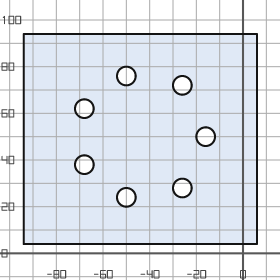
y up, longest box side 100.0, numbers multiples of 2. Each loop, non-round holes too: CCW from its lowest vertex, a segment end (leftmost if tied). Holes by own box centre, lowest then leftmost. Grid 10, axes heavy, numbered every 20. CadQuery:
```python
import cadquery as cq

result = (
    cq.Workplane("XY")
    .moveTo(-94.0, 4.0)
    .lineTo(6.0, 4.0)
    .lineTo(6.0, 94.0)
    .lineTo(-94.0, 94.0)
    .close()
    .moveTo(-50.0, 24.0)
    .circle(4.0)
    .moveTo(-26.0, 28.0)
    .circle(4.0)
    .moveTo(-68.0, 38.0)
    .circle(4.0)
    .moveTo(-16.0, 50.0)
    .circle(4.0)
    .moveTo(-68.0, 62.0)
    .circle(4.0)
    .moveTo(-26.0, 72.0)
    .circle(4.0)
    .moveTo(-50.0, 76.0)
    .circle(4.0)
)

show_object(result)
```